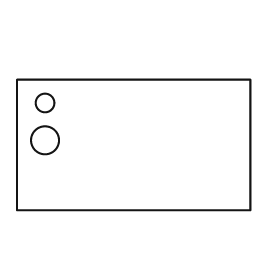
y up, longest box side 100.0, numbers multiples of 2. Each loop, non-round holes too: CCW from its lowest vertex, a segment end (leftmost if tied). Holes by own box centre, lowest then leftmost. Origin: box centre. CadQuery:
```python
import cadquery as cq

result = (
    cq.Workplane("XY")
    .moveTo(-50.0, -28.0)
    .lineTo(50.0, -28.0)
    .lineTo(50.0, 28.0)
    .lineTo(-50.0, 28.0)
    .close()
    .moveTo(-38.0, 2.0)
    .circle(6.0)
    .moveTo(-38.0, 18.0)
    .circle(4.0)
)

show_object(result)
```